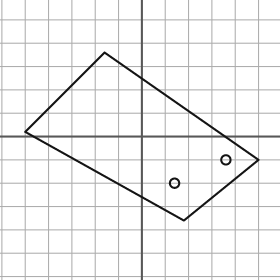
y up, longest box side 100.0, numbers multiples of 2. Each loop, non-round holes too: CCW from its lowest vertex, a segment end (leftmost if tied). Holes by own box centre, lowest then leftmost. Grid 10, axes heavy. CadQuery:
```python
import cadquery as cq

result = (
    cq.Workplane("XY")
    .moveTo(18.0, -36.0)
    .lineTo(50.0, -10.0)
    .lineTo(-16.0, 36.0)
    .lineTo(-50.0, 2.0)
    .close()
    .moveTo(14.0, -20.0)
    .circle(2.0)
    .moveTo(36.0, -10.0)
    .circle(2.0)
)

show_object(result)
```